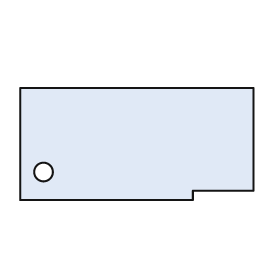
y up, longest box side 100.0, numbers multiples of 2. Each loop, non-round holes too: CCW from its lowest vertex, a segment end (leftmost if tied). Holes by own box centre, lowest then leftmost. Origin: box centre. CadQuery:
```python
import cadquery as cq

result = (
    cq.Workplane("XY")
    .moveTo(-50.0, -24.0)
    .lineTo(24.0, -24.0)
    .lineTo(24.0, -20.0)
    .lineTo(50.0, -20.0)
    .lineTo(50.0, 24.0)
    .lineTo(-50.0, 24.0)
    .close()
    .moveTo(-40.0, -12.0)
    .circle(4.0)
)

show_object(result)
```